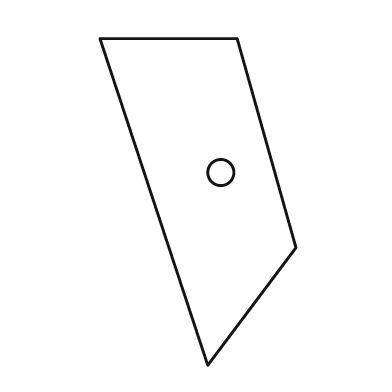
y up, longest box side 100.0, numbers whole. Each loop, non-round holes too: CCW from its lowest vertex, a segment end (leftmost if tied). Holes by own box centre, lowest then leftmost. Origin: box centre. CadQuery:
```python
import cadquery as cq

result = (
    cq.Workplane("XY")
    .moveTo(3.0, -50.0)
    .lineTo(30.0, -14.0)
    .lineTo(12.0, 50.0)
    .lineTo(-30.0, 50.0)
    .close()
    .moveTo(7.0, 9.0)
    .circle(4.0)
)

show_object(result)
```